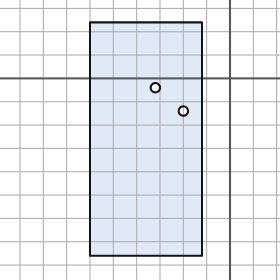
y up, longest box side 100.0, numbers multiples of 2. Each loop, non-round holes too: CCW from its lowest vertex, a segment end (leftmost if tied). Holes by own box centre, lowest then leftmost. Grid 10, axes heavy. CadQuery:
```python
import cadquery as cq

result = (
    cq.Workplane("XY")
    .moveTo(-60.0, -76.0)
    .lineTo(-12.0, -76.0)
    .lineTo(-12.0, 24.0)
    .lineTo(-60.0, 24.0)
    .close()
    .moveTo(-20.0, -14.0)
    .circle(2.0)
    .moveTo(-32.0, -4.0)
    .circle(2.0)
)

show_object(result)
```